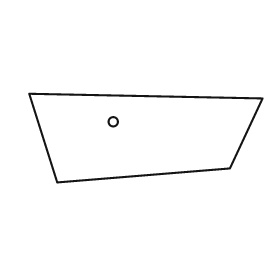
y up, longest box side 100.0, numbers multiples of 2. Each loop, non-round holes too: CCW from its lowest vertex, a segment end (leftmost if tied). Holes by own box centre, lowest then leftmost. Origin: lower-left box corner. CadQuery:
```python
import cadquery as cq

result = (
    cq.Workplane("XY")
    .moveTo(12.0, 0.0)
    .lineTo(86.0, 6.0)
    .lineTo(100.0, 36.0)
    .lineTo(0.0, 38.0)
    .close()
    .moveTo(36.0, 26.0)
    .circle(2.0)
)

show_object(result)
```